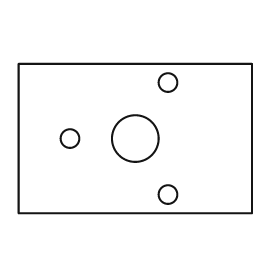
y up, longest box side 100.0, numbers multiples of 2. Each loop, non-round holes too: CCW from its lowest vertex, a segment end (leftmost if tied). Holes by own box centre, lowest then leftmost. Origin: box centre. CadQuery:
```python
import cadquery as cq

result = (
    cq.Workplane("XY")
    .moveTo(-50.0, -32.0)
    .lineTo(50.0, -32.0)
    .lineTo(50.0, 32.0)
    .lineTo(-50.0, 32.0)
    .close()
    .moveTo(14.0, -24.0)
    .circle(4.0)
    .moveTo(-28.0, 0.0)
    .circle(4.0)
    .moveTo(0.0, 0.0)
    .circle(10.0)
    .moveTo(14.0, 24.0)
    .circle(4.0)
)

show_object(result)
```